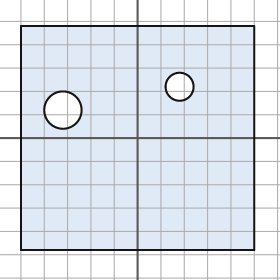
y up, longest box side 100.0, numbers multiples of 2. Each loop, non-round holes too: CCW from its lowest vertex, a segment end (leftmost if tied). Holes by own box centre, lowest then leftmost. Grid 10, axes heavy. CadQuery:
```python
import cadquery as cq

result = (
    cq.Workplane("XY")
    .moveTo(-50.0, -48.0)
    .lineTo(50.0, -48.0)
    .lineTo(50.0, 48.0)
    .lineTo(-50.0, 48.0)
    .close()
    .moveTo(-32.0, 12.0)
    .circle(8.0)
    .moveTo(18.0, 22.0)
    .circle(6.0)
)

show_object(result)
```